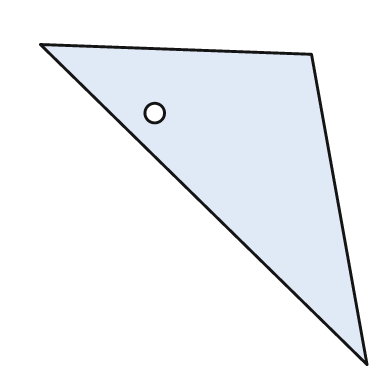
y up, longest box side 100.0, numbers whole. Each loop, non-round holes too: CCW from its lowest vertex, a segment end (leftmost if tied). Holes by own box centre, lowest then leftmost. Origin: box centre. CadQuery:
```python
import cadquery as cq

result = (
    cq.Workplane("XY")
    .moveTo(50.0, -49.0)
    .lineTo(33.0, 46.0)
    .lineTo(-50.0, 49.0)
    .close()
    .moveTo(-15.0, 28.0)
    .circle(3.0)
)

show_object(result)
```